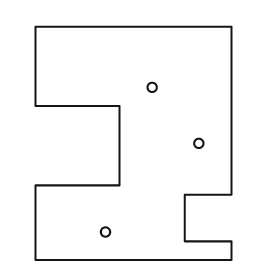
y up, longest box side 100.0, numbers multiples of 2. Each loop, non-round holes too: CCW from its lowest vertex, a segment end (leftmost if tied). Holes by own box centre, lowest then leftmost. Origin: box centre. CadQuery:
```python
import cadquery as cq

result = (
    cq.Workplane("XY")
    .moveTo(-42.0, -50.0)
    .lineTo(42.0, -50.0)
    .lineTo(42.0, -42.0)
    .lineTo(22.0, -42.0)
    .lineTo(22.0, -22.0)
    .lineTo(42.0, -22.0)
    .lineTo(42.0, 50.0)
    .lineTo(-42.0, 50.0)
    .lineTo(-42.0, 16.0)
    .lineTo(-6.0, 16.0)
    .lineTo(-6.0, -18.0)
    .lineTo(-42.0, -18.0)
    .close()
    .moveTo(-12.0, -38.0)
    .circle(2.0)
    .moveTo(28.0, 0.0)
    .circle(2.0)
    .moveTo(8.0, 24.0)
    .circle(2.0)
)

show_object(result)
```